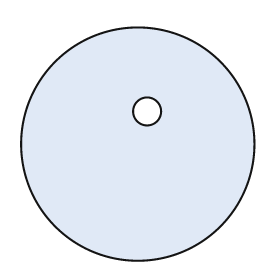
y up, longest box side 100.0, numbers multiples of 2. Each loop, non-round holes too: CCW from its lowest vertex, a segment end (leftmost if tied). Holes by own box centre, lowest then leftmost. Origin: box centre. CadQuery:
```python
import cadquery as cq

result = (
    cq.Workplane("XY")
    .moveTo(0.0, 0.0)
    .circle(50.0)
    .moveTo(4.0, 14.0)
    .circle(6.0)
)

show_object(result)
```